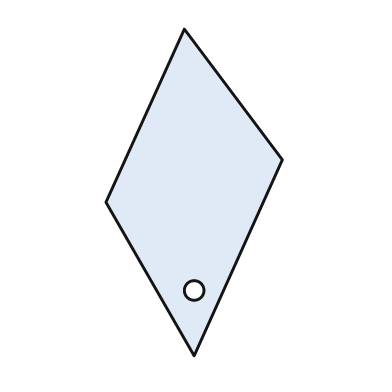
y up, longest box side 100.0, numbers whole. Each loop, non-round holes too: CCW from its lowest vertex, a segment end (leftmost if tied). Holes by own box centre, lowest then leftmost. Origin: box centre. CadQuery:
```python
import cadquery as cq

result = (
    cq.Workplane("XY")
    .moveTo(0.0, -50.0)
    .lineTo(27.0, 10.0)
    .lineTo(-3.0, 50.0)
    .lineTo(-27.0, -3.0)
    .close()
    .moveTo(0.0, -30.0)
    .circle(3.0)
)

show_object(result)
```